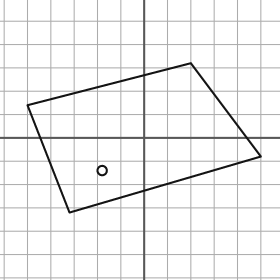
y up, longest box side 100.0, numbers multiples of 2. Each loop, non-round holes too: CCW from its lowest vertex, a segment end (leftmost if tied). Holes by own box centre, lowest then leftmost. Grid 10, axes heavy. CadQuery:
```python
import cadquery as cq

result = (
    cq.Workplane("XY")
    .moveTo(-32.0, -32.0)
    .lineTo(50.0, -8.0)
    .lineTo(20.0, 32.0)
    .lineTo(-50.0, 14.0)
    .close()
    .moveTo(-18.0, -14.0)
    .circle(2.0)
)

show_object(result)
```